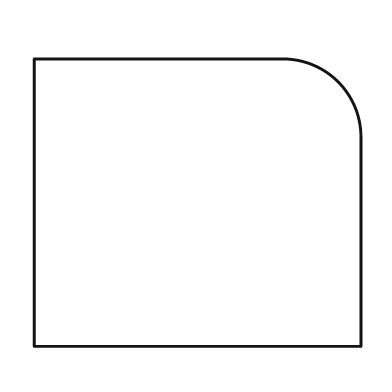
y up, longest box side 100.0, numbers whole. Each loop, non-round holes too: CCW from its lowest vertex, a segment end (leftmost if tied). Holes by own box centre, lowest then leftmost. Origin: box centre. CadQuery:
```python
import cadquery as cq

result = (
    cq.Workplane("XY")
    .moveTo(-50.0, -44.0)
    .lineTo(50.0, -44.0)
    .lineTo(50.0, 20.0)
    .threePointArc((43.0, 37.0), (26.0, 44.0))
    .lineTo(-50.0, 44.0)
    .close()
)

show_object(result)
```